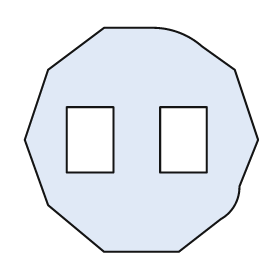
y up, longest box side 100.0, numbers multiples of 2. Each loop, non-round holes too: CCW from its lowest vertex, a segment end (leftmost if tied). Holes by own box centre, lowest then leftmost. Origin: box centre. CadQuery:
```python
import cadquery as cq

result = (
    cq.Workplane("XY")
    .moveTo(-16.0, -48.0)
    .lineTo(16.0, -48.0)
    .lineTo(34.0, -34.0)
    .threePointArc((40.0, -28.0), (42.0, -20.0))
    .lineTo(50.0, 0.0)
    .lineTo(40.0, 30.0)
    .lineTo(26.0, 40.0)
    .threePointArc((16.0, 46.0), (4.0, 48.0))
    .lineTo(-16.0, 48.0)
    .lineTo(-40.0, 30.0)
    .lineTo(-50.0, 0.0)
    .lineTo(-40.0, -28.0)
    .close()
    .moveTo(-32.0, -14.0)
    .lineTo(-12.0, -14.0)
    .lineTo(-12.0, 14.0)
    .lineTo(-32.0, 14.0)
    .close()
    .moveTo(8.0, -14.0)
    .lineTo(28.0, -14.0)
    .lineTo(28.0, 14.0)
    .lineTo(8.0, 14.0)
    .close()
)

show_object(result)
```